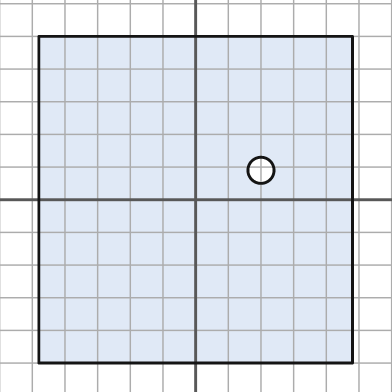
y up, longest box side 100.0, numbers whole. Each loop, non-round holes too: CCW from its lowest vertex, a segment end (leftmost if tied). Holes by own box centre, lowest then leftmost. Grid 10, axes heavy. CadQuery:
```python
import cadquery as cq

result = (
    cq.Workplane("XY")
    .moveTo(-48.0, -50.0)
    .lineTo(48.0, -50.0)
    .lineTo(48.0, 50.0)
    .lineTo(-48.0, 50.0)
    .close()
    .moveTo(20.0, 9.0)
    .circle(4.0)
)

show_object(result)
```